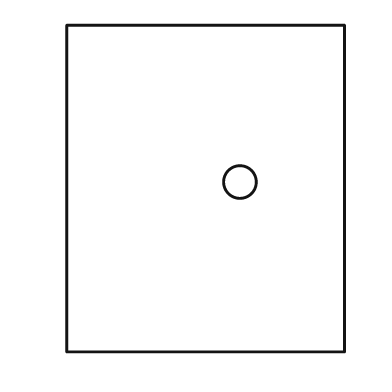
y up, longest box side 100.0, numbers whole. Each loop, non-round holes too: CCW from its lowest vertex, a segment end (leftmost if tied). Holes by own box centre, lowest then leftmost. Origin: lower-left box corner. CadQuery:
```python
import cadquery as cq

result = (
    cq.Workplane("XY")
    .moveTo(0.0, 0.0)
    .lineTo(85.0, 0.0)
    .lineTo(85.0, 100.0)
    .lineTo(0.0, 100.0)
    .close()
    .moveTo(53.0, 52.0)
    .circle(5.0)
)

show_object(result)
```